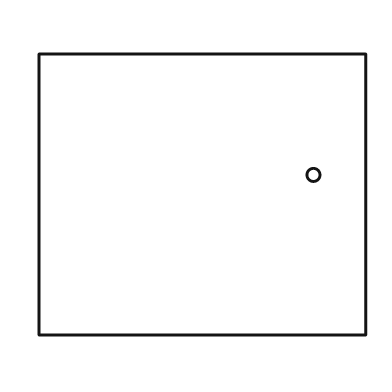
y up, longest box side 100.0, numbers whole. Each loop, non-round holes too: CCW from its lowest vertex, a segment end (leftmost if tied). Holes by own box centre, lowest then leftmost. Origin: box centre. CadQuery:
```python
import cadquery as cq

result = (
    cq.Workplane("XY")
    .moveTo(-50.0, -43.0)
    .lineTo(50.0, -43.0)
    .lineTo(50.0, 43.0)
    .lineTo(-50.0, 43.0)
    .close()
    .moveTo(34.0, 6.0)
    .circle(2.0)
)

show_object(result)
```